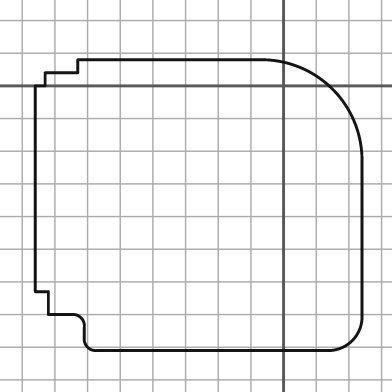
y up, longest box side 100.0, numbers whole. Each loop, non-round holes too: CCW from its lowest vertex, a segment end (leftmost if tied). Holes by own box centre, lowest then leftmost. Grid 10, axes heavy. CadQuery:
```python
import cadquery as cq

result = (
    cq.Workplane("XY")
    .moveTo(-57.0, -81.0)
    .lineTo(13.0, -81.0)
    .threePointArc((21.0, -78.0), (24.0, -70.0))
    .lineTo(24.0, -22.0)
    .threePointArc((15.0, -1.0), (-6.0, 8.0))
    .lineTo(-63.0, 8.0)
    .lineTo(-63.0, 4.0)
    .lineTo(-73.0, 4.0)
    .lineTo(-73.0, 0.0)
    .lineTo(-76.0, 0.0)
    .lineTo(-76.0, -63.0)
    .lineTo(-72.0, -63.0)
    .lineTo(-72.0, -70.0)
    .lineTo(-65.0, -70.0)
    .threePointArc((-62.0, -71.0), (-61.0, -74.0))
    .lineTo(-61.0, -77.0)
    .threePointArc((-60.0, -80.0), (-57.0, -81.0))
    .close()
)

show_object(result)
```